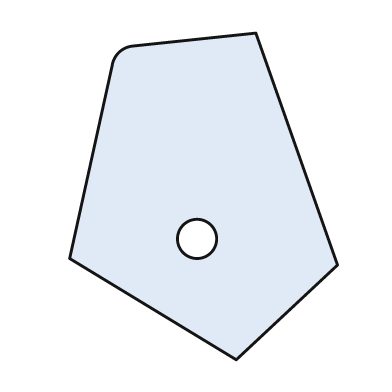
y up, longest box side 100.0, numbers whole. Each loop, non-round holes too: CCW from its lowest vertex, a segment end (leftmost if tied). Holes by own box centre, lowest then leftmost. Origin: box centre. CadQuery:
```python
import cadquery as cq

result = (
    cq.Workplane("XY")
    .moveTo(10.0, -50.0)
    .lineTo(41.0, -21.0)
    .lineTo(16.0, 50.0)
    .lineTo(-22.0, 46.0)
    .threePointArc((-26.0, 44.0), (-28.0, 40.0))
    .lineTo(-41.0, -19.0)
    .close()
    .moveTo(-2.0, -13.0)
    .circle(6.0)
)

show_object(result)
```